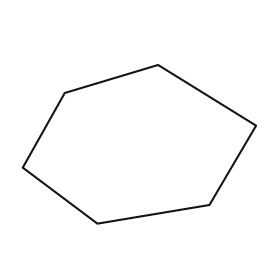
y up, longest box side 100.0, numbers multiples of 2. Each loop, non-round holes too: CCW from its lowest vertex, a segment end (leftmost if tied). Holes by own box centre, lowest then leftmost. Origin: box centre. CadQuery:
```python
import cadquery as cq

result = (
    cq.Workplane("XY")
    .moveTo(-18.0, -34.0)
    .lineTo(30.0, -26.0)
    .lineTo(50.0, 8.0)
    .lineTo(8.0, 34.0)
    .lineTo(-32.0, 22.0)
    .lineTo(-50.0, -10.0)
    .close()
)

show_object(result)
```